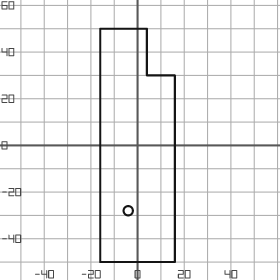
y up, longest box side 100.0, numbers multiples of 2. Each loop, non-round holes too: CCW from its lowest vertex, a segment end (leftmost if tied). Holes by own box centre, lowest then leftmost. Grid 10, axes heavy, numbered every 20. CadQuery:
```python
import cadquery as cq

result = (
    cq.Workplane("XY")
    .moveTo(-16.0, -50.0)
    .lineTo(16.0, -50.0)
    .lineTo(16.0, 30.0)
    .lineTo(4.0, 30.0)
    .lineTo(4.0, 50.0)
    .lineTo(-16.0, 50.0)
    .close()
    .moveTo(-4.0, -28.0)
    .circle(2.0)
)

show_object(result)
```